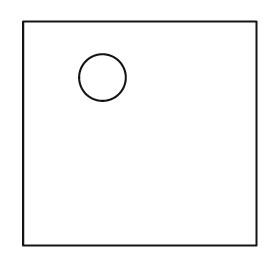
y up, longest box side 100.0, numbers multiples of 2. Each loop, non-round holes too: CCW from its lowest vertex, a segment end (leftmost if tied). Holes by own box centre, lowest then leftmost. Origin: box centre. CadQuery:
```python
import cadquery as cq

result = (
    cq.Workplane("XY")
    .moveTo(-50.0, -48.0)
    .lineTo(50.0, -48.0)
    .lineTo(50.0, 48.0)
    .lineTo(-50.0, 48.0)
    .close()
    .moveTo(-16.0, 24.0)
    .circle(10.0)
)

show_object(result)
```